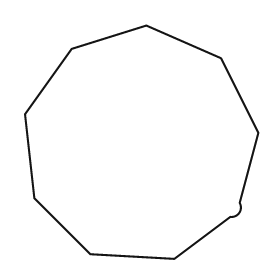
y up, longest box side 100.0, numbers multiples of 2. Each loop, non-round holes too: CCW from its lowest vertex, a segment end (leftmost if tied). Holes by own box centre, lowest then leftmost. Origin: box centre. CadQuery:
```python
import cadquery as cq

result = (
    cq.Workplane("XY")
    .moveTo(14.0, -50.0)
    .lineTo(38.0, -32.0)
    .threePointArc((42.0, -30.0), (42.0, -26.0))
    .lineTo(50.0, 4.0)
    .lineTo(34.0, 36.0)
    .lineTo(2.0, 50.0)
    .lineTo(-30.0, 40.0)
    .lineTo(-50.0, 12.0)
    .lineTo(-46.0, -24.0)
    .lineTo(-22.0, -48.0)
    .close()
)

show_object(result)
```